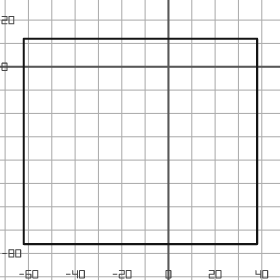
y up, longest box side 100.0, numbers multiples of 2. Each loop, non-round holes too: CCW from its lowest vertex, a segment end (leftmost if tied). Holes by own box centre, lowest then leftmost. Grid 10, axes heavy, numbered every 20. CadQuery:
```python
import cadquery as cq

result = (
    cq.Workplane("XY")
    .moveTo(-62.0, -76.0)
    .lineTo(38.0, -76.0)
    .lineTo(38.0, 12.0)
    .lineTo(-62.0, 12.0)
    .close()
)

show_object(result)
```